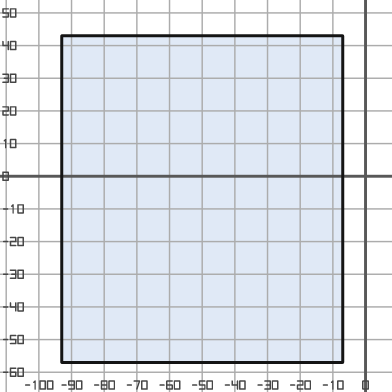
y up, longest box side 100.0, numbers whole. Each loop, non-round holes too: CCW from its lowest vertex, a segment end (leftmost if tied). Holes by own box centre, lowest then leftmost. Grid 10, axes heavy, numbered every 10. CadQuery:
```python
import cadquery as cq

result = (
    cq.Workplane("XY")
    .moveTo(-93.0, -57.0)
    .lineTo(-7.0, -57.0)
    .lineTo(-7.0, 43.0)
    .lineTo(-93.0, 43.0)
    .close()
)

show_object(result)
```